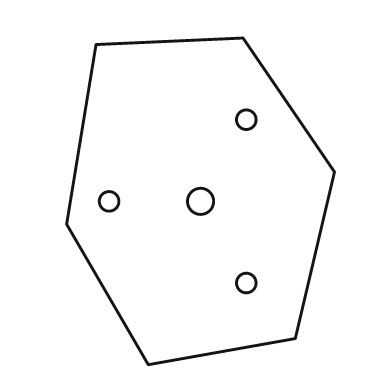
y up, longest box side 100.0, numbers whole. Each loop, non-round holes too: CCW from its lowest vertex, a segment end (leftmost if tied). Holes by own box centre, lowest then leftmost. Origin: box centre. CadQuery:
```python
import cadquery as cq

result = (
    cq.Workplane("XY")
    .moveTo(-16.0, -50.0)
    .lineTo(29.0, -42.0)
    .lineTo(41.0, 9.0)
    .lineTo(13.0, 50.0)
    .lineTo(-32.0, 48.0)
    .lineTo(-41.0, -7.0)
    .close()
    .moveTo(14.0, -25.0)
    .circle(3.0)
    .moveTo(-28.0, 0.0)
    .circle(3.0)
    .moveTo(0.0, 0.0)
    .circle(4.0)
    .moveTo(14.0, 25.0)
    .circle(3.0)
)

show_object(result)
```